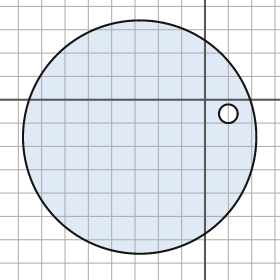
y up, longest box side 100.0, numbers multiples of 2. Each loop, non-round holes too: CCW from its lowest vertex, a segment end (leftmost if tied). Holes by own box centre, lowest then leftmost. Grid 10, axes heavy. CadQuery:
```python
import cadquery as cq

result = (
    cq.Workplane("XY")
    .moveTo(-28.0, -16.0)
    .circle(50.0)
    .moveTo(10.0, -6.0)
    .circle(4.0)
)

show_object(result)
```